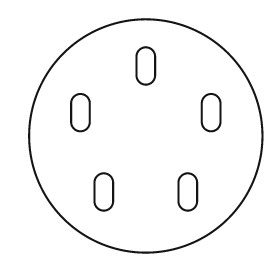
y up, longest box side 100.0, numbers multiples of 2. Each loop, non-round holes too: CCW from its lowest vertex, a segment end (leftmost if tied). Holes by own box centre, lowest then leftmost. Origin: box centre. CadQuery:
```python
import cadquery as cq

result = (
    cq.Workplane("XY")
    .moveTo(0.0, 0.0)
    .circle(50.0)
    .moveTo(-22.0, -28.0)
    .threePointArc((-18.0, -32.0), (-14.0, -28.0))
    .lineTo(-14.0, -20.0)
    .threePointArc((-18.0, -16.0), (-22.0, -20.0))
    .close()
    .moveTo(14.0, -28.0)
    .threePointArc((18.0, -32.0), (22.0, -28.0))
    .lineTo(22.0, -20.0)
    .threePointArc((18.0, -16.0), (14.0, -20.0))
    .close()
    .moveTo(-32.0, 6.0)
    .threePointArc((-28.0, 2.0), (-24.0, 6.0))
    .lineTo(-24.0, 14.0)
    .threePointArc((-28.0, 18.0), (-32.0, 14.0))
    .close()
    .moveTo(24.0, 6.0)
    .threePointArc((28.0, 2.0), (32.0, 6.0))
    .lineTo(32.0, 14.0)
    .threePointArc((28.0, 18.0), (24.0, 14.0))
    .close()
    .moveTo(-4.0, 26.0)
    .threePointArc((0.0, 22.0), (4.0, 26.0))
    .lineTo(4.0, 34.0)
    .threePointArc((0.0, 38.0), (-4.0, 34.0))
    .close()
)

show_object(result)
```